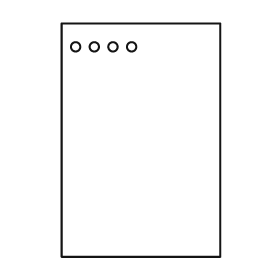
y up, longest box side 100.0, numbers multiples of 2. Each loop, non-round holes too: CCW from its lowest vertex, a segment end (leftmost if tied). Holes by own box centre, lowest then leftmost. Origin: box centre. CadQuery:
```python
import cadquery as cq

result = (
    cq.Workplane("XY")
    .moveTo(-34.0, -50.0)
    .lineTo(34.0, -50.0)
    .lineTo(34.0, 50.0)
    .lineTo(-34.0, 50.0)
    .close()
    .moveTo(-28.0, 40.0)
    .circle(2.0)
    .moveTo(-20.0, 40.0)
    .circle(2.0)
    .moveTo(-12.0, 40.0)
    .circle(2.0)
    .moveTo(-4.0, 40.0)
    .circle(2.0)
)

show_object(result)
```